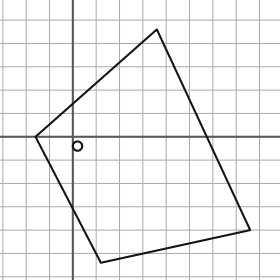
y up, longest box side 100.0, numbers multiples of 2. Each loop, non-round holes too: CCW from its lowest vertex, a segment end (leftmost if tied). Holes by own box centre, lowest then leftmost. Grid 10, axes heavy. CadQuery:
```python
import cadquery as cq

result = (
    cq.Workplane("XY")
    .moveTo(12.0, -54.0)
    .lineTo(76.0, -40.0)
    .lineTo(36.0, 46.0)
    .lineTo(-16.0, 0.0)
    .close()
    .moveTo(2.0, -4.0)
    .circle(2.0)
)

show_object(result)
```